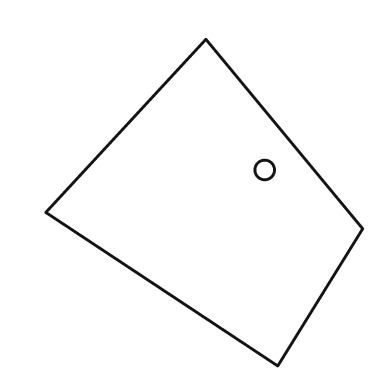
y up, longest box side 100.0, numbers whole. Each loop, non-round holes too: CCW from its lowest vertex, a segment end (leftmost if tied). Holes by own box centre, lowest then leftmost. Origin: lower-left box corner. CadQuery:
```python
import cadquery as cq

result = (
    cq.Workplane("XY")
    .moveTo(71.0, 0.0)
    .lineTo(97.0, 42.0)
    .lineTo(49.0, 100.0)
    .lineTo(0.0, 47.0)
    .close()
    .moveTo(67.0, 60.0)
    .circle(3.0)
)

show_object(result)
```